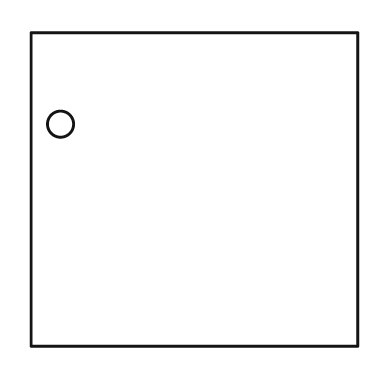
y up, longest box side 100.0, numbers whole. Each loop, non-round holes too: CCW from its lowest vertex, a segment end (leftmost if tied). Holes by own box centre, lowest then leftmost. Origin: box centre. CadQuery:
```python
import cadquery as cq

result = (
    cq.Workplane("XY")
    .moveTo(-50.0, -48.0)
    .lineTo(50.0, -48.0)
    .lineTo(50.0, 48.0)
    .lineTo(-50.0, 48.0)
    .close()
    .moveTo(-41.0, 20.0)
    .circle(4.0)
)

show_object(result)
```